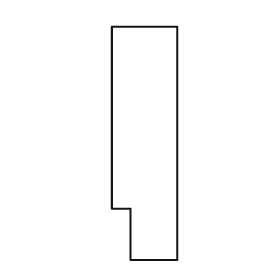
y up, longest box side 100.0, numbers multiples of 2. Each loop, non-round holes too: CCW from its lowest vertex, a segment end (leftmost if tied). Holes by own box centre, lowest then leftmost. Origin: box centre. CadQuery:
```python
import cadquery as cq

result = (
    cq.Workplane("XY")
    .moveTo(-6.0, -50.0)
    .lineTo(14.0, -50.0)
    .lineTo(14.0, 50.0)
    .lineTo(-14.0, 50.0)
    .lineTo(-14.0, -28.0)
    .lineTo(-6.0, -28.0)
    .close()
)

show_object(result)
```